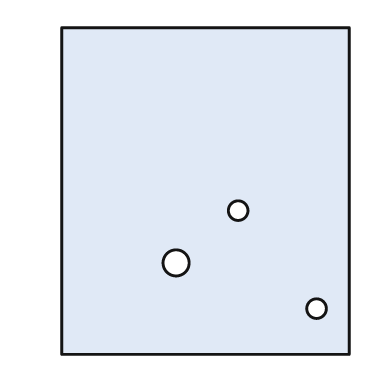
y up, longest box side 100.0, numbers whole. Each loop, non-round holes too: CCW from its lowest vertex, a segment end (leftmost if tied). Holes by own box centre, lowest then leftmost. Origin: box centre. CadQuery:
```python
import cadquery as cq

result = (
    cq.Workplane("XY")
    .moveTo(-44.0, -50.0)
    .lineTo(44.0, -50.0)
    .lineTo(44.0, 50.0)
    .lineTo(-44.0, 50.0)
    .close()
    .moveTo(34.0, -36.0)
    .circle(3.0)
    .moveTo(-9.0, -22.0)
    .circle(4.0)
    .moveTo(10.0, -6.0)
    .circle(3.0)
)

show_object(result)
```